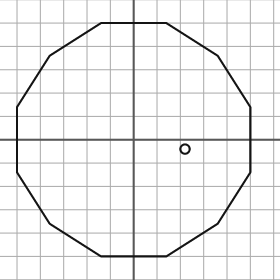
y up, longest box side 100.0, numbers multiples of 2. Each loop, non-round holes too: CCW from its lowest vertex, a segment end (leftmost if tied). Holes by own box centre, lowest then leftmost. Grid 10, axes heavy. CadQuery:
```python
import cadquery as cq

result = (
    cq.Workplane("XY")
    .moveTo(-14.0, -50.0)
    .lineTo(14.0, -50.0)
    .lineTo(36.0, -36.0)
    .lineTo(50.0, -14.0)
    .lineTo(50.0, 14.0)
    .lineTo(36.0, 36.0)
    .lineTo(14.0, 50.0)
    .lineTo(-14.0, 50.0)
    .lineTo(-36.0, 36.0)
    .lineTo(-50.0, 14.0)
    .lineTo(-50.0, -14.0)
    .lineTo(-36.0, -36.0)
    .close()
    .moveTo(22.0, -4.0)
    .circle(2.0)
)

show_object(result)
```